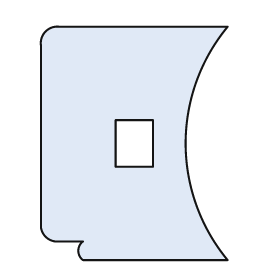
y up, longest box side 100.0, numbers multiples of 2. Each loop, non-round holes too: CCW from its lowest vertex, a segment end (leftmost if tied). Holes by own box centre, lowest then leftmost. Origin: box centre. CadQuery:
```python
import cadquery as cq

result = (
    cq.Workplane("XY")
    .moveTo(-22.0, -50.0)
    .lineTo(40.0, -50.0)
    .threePointArc((22.0, 0.0), (40.0, 50.0))
    .lineTo(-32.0, 50.0)
    .threePointArc((-38.0, 48.0), (-40.0, 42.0))
    .lineTo(-40.0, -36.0)
    .threePointArc((-38.0, -40.0), (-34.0, -42.0))
    .lineTo(-22.0, -42.0)
    .threePointArc((-24.0, -46.0), (-22.0, -50.0))
    .close()
    .moveTo(-8.0, -10.0)
    .lineTo(8.0, -10.0)
    .lineTo(8.0, 10.0)
    .lineTo(-8.0, 10.0)
    .close()
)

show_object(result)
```